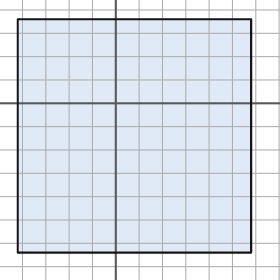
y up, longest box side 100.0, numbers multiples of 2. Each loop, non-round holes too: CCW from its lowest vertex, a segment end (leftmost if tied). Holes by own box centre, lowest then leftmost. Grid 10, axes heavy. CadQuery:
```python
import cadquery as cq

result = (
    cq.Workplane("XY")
    .moveTo(-42.0, -64.0)
    .lineTo(58.0, -64.0)
    .lineTo(58.0, 36.0)
    .lineTo(-42.0, 36.0)
    .close()
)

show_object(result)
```